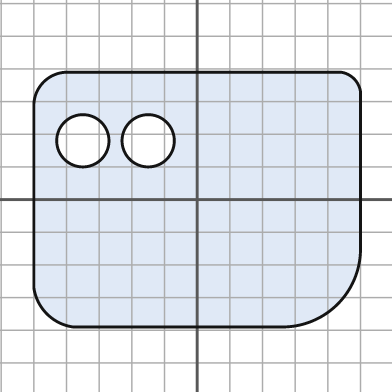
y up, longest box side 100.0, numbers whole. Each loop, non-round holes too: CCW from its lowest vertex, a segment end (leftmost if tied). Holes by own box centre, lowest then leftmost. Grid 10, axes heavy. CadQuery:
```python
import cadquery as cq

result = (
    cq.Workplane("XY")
    .moveTo(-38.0, -39.0)
    .lineTo(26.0, -39.0)
    .threePointArc((43.0, -32.0), (50.0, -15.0))
    .lineTo(50.0, 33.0)
    .threePointArc((48.0, 37.0), (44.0, 39.0))
    .lineTo(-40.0, 39.0)
    .threePointArc((-47.0, 36.0), (-50.0, 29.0))
    .lineTo(-50.0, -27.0)
    .threePointArc((-46.0, -35.0), (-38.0, -39.0))
    .close()
    .moveTo(-35.0, 18.0)
    .circle(8.0)
    .moveTo(-15.0, 18.0)
    .circle(8.0)
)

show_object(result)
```